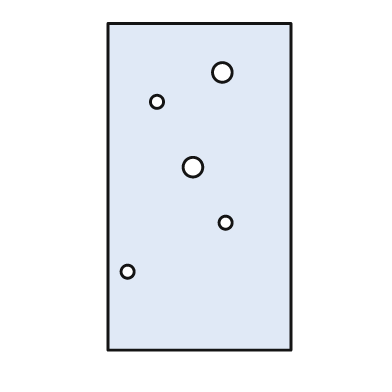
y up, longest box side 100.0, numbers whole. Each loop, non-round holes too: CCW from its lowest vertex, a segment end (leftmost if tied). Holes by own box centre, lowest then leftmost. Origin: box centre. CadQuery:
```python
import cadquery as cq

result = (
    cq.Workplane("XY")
    .moveTo(-28.0, -50.0)
    .lineTo(28.0, -50.0)
    .lineTo(28.0, 50.0)
    .lineTo(-28.0, 50.0)
    .close()
    .moveTo(-22.0, -26.0)
    .circle(2.0)
    .moveTo(8.0, -11.0)
    .circle(2.0)
    .moveTo(-2.0, 6.0)
    .circle(3.0)
    .moveTo(-13.0, 26.0)
    .circle(2.0)
    .moveTo(7.0, 35.0)
    .circle(3.0)
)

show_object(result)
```